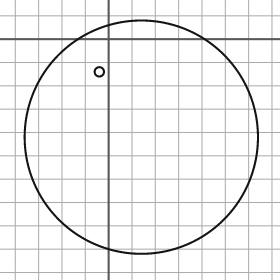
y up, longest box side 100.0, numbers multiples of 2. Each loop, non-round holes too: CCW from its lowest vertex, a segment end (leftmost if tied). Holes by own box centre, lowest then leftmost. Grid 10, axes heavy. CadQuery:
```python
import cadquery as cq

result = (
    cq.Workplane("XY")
    .moveTo(14.0, -42.0)
    .circle(50.0)
    .moveTo(-4.0, -14.0)
    .circle(2.0)
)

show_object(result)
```